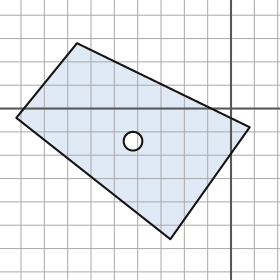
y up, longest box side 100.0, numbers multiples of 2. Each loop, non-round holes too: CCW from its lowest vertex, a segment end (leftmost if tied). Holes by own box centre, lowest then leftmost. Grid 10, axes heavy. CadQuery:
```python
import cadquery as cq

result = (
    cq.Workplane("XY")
    .moveTo(-26.0, -56.0)
    .lineTo(8.0, -8.0)
    .lineTo(-66.0, 28.0)
    .lineTo(-92.0, -4.0)
    .close()
    .moveTo(-42.0, -14.0)
    .circle(4.0)
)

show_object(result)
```